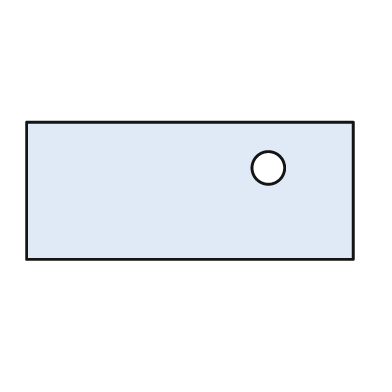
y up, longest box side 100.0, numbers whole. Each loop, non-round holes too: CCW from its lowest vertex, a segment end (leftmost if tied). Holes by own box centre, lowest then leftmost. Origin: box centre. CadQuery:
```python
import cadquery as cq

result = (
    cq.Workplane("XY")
    .moveTo(-50.0, -21.0)
    .lineTo(50.0, -21.0)
    .lineTo(50.0, 21.0)
    .lineTo(-50.0, 21.0)
    .close()
    .moveTo(24.0, 7.0)
    .circle(5.0)
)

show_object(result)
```